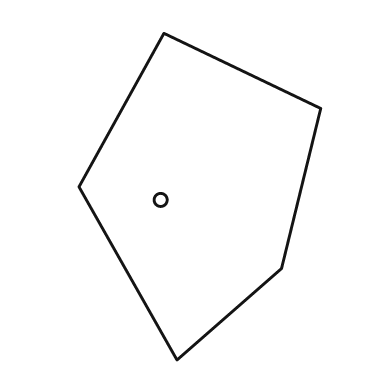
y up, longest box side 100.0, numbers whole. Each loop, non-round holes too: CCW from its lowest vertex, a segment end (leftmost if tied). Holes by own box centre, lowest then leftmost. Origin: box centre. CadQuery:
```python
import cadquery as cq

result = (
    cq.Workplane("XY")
    .moveTo(-7.0, -50.0)
    .lineTo(25.0, -22.0)
    .lineTo(37.0, 27.0)
    .lineTo(-11.0, 50.0)
    .lineTo(-37.0, 3.0)
    .close()
    .moveTo(-12.0, -1.0)
    .circle(2.0)
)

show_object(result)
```